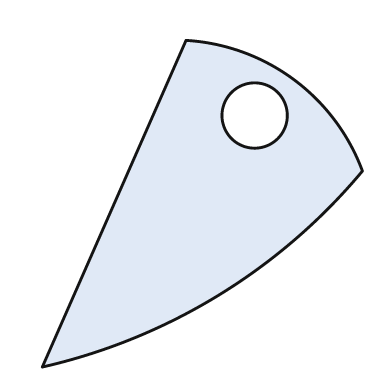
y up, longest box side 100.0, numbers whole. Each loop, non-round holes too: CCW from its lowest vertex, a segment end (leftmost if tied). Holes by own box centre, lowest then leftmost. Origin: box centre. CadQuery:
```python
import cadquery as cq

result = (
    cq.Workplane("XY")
    .moveTo(-49.0, -50.0)
    .threePointArc((5.0, -28.0), (49.0, 10.0))
    .threePointArc((28.0, 38.0), (-5.0, 50.0))
    .close()
    .moveTo(16.0, 27.0)
    .circle(10.0)
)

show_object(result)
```